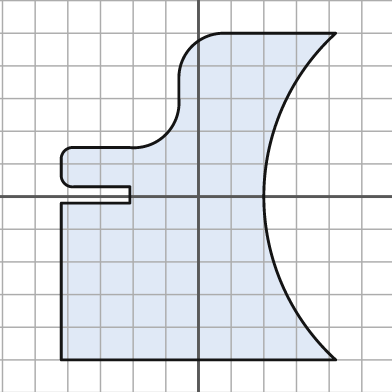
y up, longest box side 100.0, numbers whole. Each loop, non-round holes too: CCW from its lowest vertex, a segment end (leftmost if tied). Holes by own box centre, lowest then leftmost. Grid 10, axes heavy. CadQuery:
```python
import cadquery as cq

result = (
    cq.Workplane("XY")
    .moveTo(-42.0, -50.0)
    .lineTo(42.0, -50.0)
    .threePointArc((20.0, 0.0), (42.0, 50.0))
    .lineTo(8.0, 50.0)
    .threePointArc((-2.0, 46.0), (-6.0, 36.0))
    .lineTo(-6.0, 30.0)
    .threePointArc((-10.0, 19.0), (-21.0, 15.0))
    .lineTo(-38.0, 15.0)
    .threePointArc((-41.0, 14.0), (-42.0, 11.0))
    .lineTo(-42.0, 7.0)
    .threePointArc((-41.0, 4.0), (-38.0, 3.0))
    .lineTo(-21.0, 3.0)
    .lineTo(-21.0, -2.0)
    .lineTo(-42.0, -2.0)
    .close()
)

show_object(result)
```